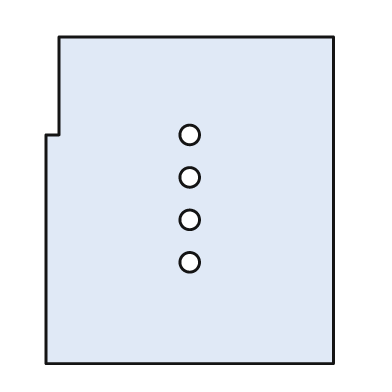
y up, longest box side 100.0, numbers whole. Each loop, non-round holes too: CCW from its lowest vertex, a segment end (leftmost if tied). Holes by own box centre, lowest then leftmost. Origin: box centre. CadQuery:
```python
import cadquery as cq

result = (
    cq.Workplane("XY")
    .moveTo(-44.0, -50.0)
    .lineTo(44.0, -50.0)
    .lineTo(44.0, 50.0)
    .lineTo(-40.0, 50.0)
    .lineTo(-40.0, 20.0)
    .lineTo(-44.0, 20.0)
    .close()
    .moveTo(0.0, -19.0)
    .circle(3.0)
    .moveTo(0.0, -6.0)
    .circle(3.0)
    .moveTo(0.0, 7.0)
    .circle(3.0)
    .moveTo(0.0, 20.0)
    .circle(3.0)
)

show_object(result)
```